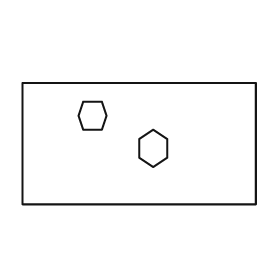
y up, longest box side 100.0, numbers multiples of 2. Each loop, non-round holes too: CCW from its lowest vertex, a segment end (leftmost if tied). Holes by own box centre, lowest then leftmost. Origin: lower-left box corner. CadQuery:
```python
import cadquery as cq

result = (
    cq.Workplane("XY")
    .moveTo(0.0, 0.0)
    .lineTo(100.0, 0.0)
    .lineTo(100.0, 52.0)
    .lineTo(0.0, 52.0)
    .close()
    .moveTo(56.0, 16.0)
    .lineTo(62.0, 20.0)
    .lineTo(62.0, 28.0)
    .lineTo(56.0, 32.0)
    .lineTo(50.0, 28.0)
    .lineTo(50.0, 20.0)
    .close()
    .moveTo(26.0, 32.0)
    .lineTo(34.0, 32.0)
    .lineTo(36.0, 38.0)
    .lineTo(34.0, 44.0)
    .lineTo(26.0, 44.0)
    .lineTo(24.0, 38.0)
    .close()
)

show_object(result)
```